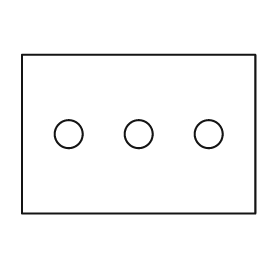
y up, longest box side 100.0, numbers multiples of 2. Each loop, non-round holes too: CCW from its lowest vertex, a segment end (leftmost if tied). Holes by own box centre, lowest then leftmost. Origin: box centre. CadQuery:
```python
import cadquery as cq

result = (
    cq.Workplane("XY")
    .moveTo(-50.0, -34.0)
    .lineTo(50.0, -34.0)
    .lineTo(50.0, 34.0)
    .lineTo(-50.0, 34.0)
    .close()
    .moveTo(-30.0, 0.0)
    .circle(6.0)
    .moveTo(0.0, 0.0)
    .circle(6.0)
    .moveTo(30.0, 0.0)
    .circle(6.0)
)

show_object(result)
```